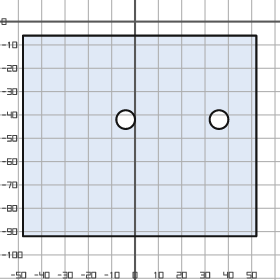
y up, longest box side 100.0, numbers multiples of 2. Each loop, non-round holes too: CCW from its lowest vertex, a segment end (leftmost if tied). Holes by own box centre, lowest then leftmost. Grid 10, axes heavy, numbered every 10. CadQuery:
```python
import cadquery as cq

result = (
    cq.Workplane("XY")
    .moveTo(-48.0, -92.0)
    .lineTo(52.0, -92.0)
    .lineTo(52.0, -6.0)
    .lineTo(-48.0, -6.0)
    .close()
    .moveTo(-4.0, -42.0)
    .circle(4.0)
    .moveTo(36.0, -42.0)
    .circle(4.0)
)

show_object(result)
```